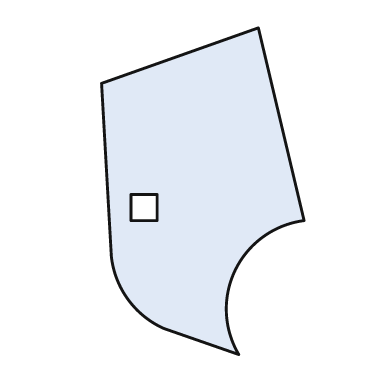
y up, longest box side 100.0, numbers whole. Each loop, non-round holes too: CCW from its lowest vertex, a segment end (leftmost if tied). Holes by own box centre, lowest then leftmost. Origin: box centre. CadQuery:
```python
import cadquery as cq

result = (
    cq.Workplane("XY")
    .moveTo(11.0, -50.0)
    .threePointArc((10.0, -24.0), (31.0, -9.0))
    .lineTo(17.0, 50.0)
    .lineTo(-31.0, 33.0)
    .lineTo(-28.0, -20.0)
    .threePointArc((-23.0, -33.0), (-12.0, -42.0))
    .close()
    .moveTo(-22.0, -9.0)
    .lineTo(-14.0, -9.0)
    .lineTo(-14.0, -1.0)
    .lineTo(-22.0, -1.0)
    .close()
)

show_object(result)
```